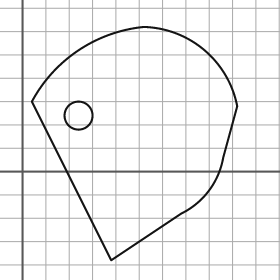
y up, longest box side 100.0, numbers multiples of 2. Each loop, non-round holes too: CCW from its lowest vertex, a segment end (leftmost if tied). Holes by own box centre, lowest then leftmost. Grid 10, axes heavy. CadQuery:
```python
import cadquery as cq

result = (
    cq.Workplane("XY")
    .moveTo(38.0, -38.0)
    .lineTo(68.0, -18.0)
    .threePointArc((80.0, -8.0), (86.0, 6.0))
    .lineTo(92.0, 28.0)
    .threePointArc((78.0, 52.0), (52.0, 62.0))
    .threePointArc((24.0, 52.0), (4.0, 30.0))
    .close()
    .moveTo(24.0, 24.0)
    .circle(6.0)
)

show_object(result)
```